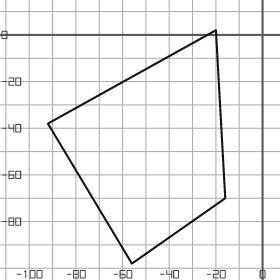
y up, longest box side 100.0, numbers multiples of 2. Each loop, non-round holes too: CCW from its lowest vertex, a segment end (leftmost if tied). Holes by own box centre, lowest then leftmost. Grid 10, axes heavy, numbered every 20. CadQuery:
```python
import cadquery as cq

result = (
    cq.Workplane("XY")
    .moveTo(-56.0, -98.0)
    .lineTo(-16.0, -70.0)
    .lineTo(-20.0, 2.0)
    .lineTo(-92.0, -38.0)
    .close()
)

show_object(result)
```